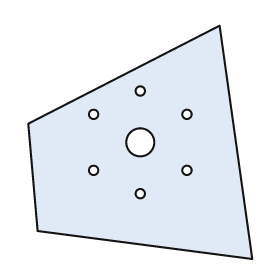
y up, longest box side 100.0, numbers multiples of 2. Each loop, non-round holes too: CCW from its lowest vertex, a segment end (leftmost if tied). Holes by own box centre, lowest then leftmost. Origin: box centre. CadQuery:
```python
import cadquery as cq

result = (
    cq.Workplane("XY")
    .moveTo(48.0, -50.0)
    .lineTo(34.0, 50.0)
    .lineTo(-48.0, 8.0)
    .lineTo(-44.0, -38.0)
    .close()
    .moveTo(0.0, -22.0)
    .circle(2.0)
    .moveTo(-20.0, -12.0)
    .circle(2.0)
    .moveTo(20.0, -12.0)
    .circle(2.0)
    .moveTo(0.0, 0.0)
    .circle(6.0)
    .moveTo(-20.0, 12.0)
    .circle(2.0)
    .moveTo(20.0, 12.0)
    .circle(2.0)
    .moveTo(0.0, 22.0)
    .circle(2.0)
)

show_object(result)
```